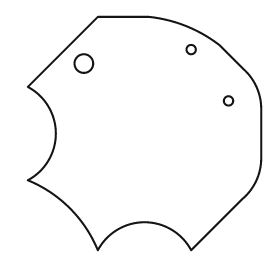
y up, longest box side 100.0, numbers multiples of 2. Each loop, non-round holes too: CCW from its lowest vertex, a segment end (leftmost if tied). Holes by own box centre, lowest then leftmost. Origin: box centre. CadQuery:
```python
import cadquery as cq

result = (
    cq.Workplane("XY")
    .moveTo(-20.0, -50.0)
    .threePointArc((0.0, -38.0), (20.0, -50.0))
    .lineTo(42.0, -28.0)
    .threePointArc((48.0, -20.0), (50.0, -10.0))
    .lineTo(50.0, 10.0)
    .threePointArc((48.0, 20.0), (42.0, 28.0))
    .lineTo(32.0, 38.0)
    .threePointArc((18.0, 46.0), (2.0, 50.0))
    .lineTo(-20.0, 50.0)
    .lineTo(-50.0, 20.0)
    .threePointArc((-38.0, 0.0), (-50.0, -20.0))
    .threePointArc((-32.0, -32.0), (-20.0, -50.0))
    .close()
    .moveTo(36.0, 14.0)
    .circle(2.0)
    .moveTo(-26.0, 30.0)
    .circle(4.0)
    .moveTo(20.0, 36.0)
    .circle(2.0)
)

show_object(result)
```